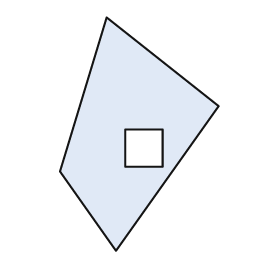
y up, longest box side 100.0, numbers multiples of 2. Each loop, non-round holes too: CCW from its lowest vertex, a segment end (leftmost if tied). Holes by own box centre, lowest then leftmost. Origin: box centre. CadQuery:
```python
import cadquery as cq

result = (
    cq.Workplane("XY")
    .moveTo(-10.0, -50.0)
    .lineTo(34.0, 12.0)
    .lineTo(-14.0, 50.0)
    .lineTo(-34.0, -16.0)
    .close()
    .moveTo(-6.0, -14.0)
    .lineTo(10.0, -14.0)
    .lineTo(10.0, 2.0)
    .lineTo(-6.0, 2.0)
    .close()
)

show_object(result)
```